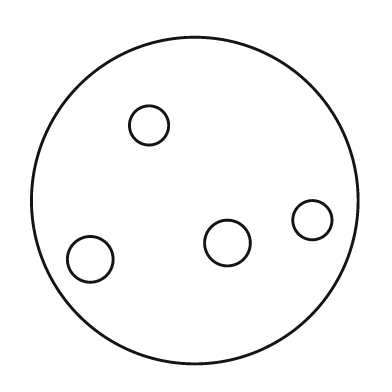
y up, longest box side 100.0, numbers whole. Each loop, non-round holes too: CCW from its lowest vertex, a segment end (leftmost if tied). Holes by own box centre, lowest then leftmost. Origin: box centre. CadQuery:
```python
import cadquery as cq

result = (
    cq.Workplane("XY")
    .moveTo(0.0, 0.0)
    .circle(50.0)
    .moveTo(-32.0, -18.0)
    .circle(7.0)
    .moveTo(10.0, -13.0)
    .circle(7.0)
    .moveTo(36.0, -6.0)
    .circle(6.0)
    .moveTo(-14.0, 23.0)
    .circle(6.0)
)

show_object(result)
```